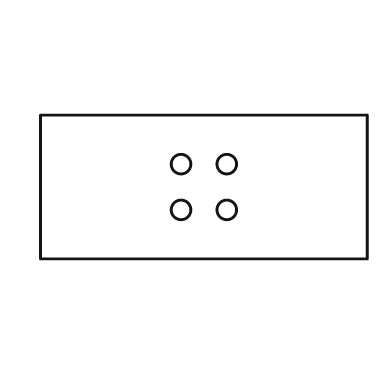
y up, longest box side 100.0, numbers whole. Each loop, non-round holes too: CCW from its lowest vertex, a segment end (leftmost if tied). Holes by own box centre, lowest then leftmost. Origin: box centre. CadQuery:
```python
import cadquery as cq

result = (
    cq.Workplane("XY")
    .moveTo(-50.0, -22.0)
    .lineTo(50.0, -22.0)
    .lineTo(50.0, 22.0)
    .lineTo(-50.0, 22.0)
    .close()
    .moveTo(-7.0, -7.0)
    .circle(3.0)
    .moveTo(7.0, -7.0)
    .circle(3.0)
    .moveTo(-7.0, 7.0)
    .circle(3.0)
    .moveTo(7.0, 7.0)
    .circle(3.0)
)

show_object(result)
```